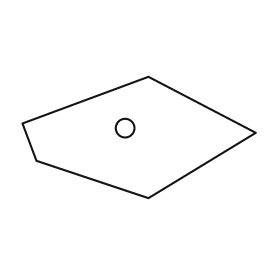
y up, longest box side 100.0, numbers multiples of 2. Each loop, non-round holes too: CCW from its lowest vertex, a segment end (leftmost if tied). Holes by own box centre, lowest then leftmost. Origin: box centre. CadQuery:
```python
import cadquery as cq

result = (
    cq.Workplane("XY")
    .moveTo(4.0, -26.0)
    .lineTo(50.0, 2.0)
    .lineTo(4.0, 26.0)
    .lineTo(-50.0, 6.0)
    .lineTo(-44.0, -10.0)
    .close()
    .moveTo(-6.0, 4.0)
    .circle(4.0)
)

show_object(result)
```